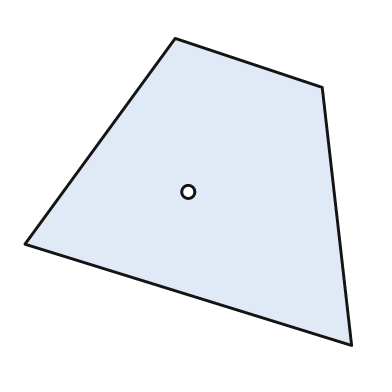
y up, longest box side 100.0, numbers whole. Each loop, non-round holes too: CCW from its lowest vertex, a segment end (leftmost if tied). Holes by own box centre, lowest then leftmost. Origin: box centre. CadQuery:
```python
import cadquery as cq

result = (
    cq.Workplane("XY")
    .moveTo(50.0, -47.0)
    .lineTo(41.0, 32.0)
    .lineTo(-4.0, 47.0)
    .lineTo(-50.0, -16.0)
    .close()
    .moveTo(0.0, 0.0)
    .circle(2.0)
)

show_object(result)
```